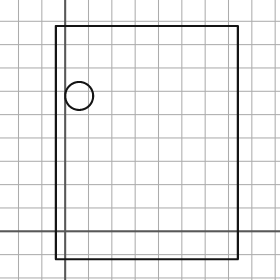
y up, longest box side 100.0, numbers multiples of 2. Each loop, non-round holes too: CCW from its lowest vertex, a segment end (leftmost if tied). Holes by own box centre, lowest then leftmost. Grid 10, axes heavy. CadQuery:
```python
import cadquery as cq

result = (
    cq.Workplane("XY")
    .moveTo(-4.0, -12.0)
    .lineTo(74.0, -12.0)
    .lineTo(74.0, 88.0)
    .lineTo(-4.0, 88.0)
    .close()
    .moveTo(6.0, 58.0)
    .circle(6.0)
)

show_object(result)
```